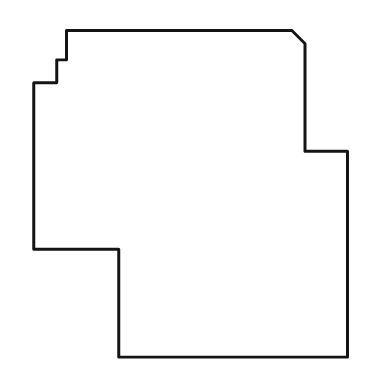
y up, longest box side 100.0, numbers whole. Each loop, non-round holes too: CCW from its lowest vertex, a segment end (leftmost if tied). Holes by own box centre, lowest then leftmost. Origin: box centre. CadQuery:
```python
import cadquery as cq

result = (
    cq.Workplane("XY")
    .moveTo(-22.0, -50.0)
    .lineTo(48.0, -50.0)
    .lineTo(48.0, 13.0)
    .lineTo(35.0, 13.0)
    .lineTo(35.0, 46.0)
    .lineTo(31.0, 50.0)
    .lineTo(-38.0, 50.0)
    .lineTo(-38.0, 41.0)
    .lineTo(-41.0, 41.0)
    .lineTo(-41.0, 34.0)
    .lineTo(-48.0, 34.0)
    .lineTo(-48.0, -17.0)
    .lineTo(-22.0, -17.0)
    .close()
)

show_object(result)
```